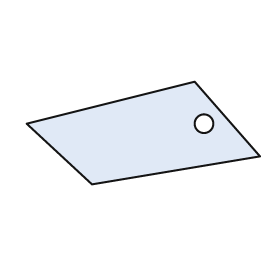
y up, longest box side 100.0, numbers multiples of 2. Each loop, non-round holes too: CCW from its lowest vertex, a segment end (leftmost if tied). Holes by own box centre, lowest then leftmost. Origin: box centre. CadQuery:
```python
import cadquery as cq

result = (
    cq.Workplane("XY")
    .moveTo(-22.0, -22.0)
    .lineTo(50.0, -10.0)
    .lineTo(22.0, 22.0)
    .lineTo(-50.0, 4.0)
    .close()
    .moveTo(26.0, 4.0)
    .circle(4.0)
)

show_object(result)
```